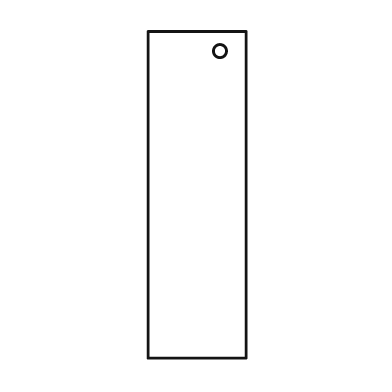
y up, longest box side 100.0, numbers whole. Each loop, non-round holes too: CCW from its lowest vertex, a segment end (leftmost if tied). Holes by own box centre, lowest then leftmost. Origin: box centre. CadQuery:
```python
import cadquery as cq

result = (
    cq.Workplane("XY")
    .moveTo(-15.0, -50.0)
    .lineTo(15.0, -50.0)
    .lineTo(15.0, 50.0)
    .lineTo(-15.0, 50.0)
    .close()
    .moveTo(7.0, 44.0)
    .circle(2.0)
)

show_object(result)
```